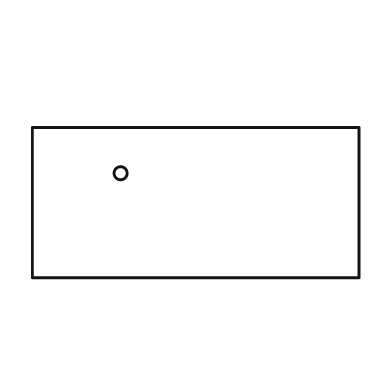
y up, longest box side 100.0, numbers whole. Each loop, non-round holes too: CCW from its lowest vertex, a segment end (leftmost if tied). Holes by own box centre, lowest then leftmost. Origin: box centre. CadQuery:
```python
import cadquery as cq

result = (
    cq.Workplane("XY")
    .moveTo(-50.0, -23.0)
    .lineTo(50.0, -23.0)
    .lineTo(50.0, 23.0)
    .lineTo(-50.0, 23.0)
    .close()
    .moveTo(-23.0, 9.0)
    .circle(2.0)
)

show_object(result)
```